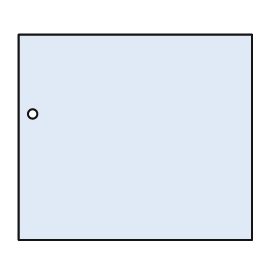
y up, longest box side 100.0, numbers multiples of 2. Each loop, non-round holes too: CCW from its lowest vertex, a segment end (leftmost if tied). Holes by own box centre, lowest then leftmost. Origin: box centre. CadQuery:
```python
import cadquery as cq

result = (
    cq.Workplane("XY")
    .moveTo(-50.0, -44.0)
    .lineTo(50.0, -44.0)
    .lineTo(50.0, 44.0)
    .lineTo(-50.0, 44.0)
    .close()
    .moveTo(-44.0, 10.0)
    .circle(2.0)
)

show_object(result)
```